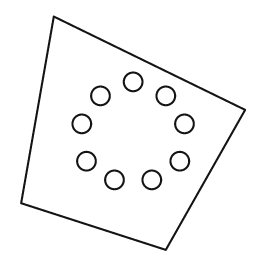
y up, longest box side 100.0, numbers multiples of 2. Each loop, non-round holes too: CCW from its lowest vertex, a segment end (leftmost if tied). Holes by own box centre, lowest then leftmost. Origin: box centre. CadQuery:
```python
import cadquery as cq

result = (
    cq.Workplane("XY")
    .moveTo(14.0, -50.0)
    .lineTo(48.0, 10.0)
    .lineTo(-34.0, 50.0)
    .lineTo(-48.0, -30.0)
    .close()
    .moveTo(-8.0, -20.0)
    .circle(4.0)
    .moveTo(8.0, -20.0)
    .circle(4.0)
    .moveTo(-20.0, -12.0)
    .circle(4.0)
    .moveTo(20.0, -12.0)
    .circle(4.0)
    .moveTo(-22.0, 4.0)
    .circle(4.0)
    .moveTo(22.0, 4.0)
    .circle(4.0)
    .moveTo(-14.0, 16.0)
    .circle(4.0)
    .moveTo(14.0, 16.0)
    .circle(4.0)
    .moveTo(0.0, 22.0)
    .circle(4.0)
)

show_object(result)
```